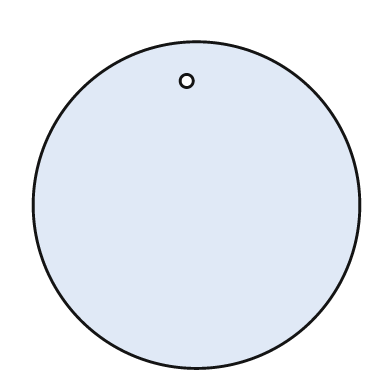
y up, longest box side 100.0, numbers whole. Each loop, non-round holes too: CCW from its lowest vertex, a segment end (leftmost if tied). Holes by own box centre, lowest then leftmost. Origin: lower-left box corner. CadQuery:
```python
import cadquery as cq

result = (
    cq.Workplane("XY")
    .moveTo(50.0, 50.0)
    .circle(50.0)
    .moveTo(47.0, 88.0)
    .circle(2.0)
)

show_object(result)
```